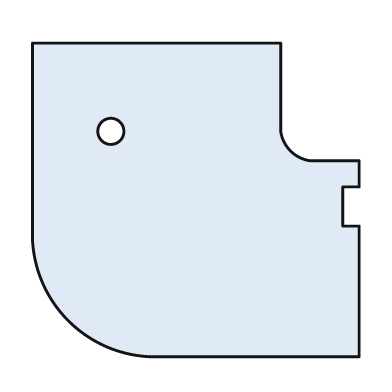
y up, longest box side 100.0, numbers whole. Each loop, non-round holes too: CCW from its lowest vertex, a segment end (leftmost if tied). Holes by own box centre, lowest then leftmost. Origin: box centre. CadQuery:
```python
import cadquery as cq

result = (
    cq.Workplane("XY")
    .moveTo(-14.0, -48.0)
    .lineTo(50.0, -48.0)
    .lineTo(50.0, -8.0)
    .lineTo(45.0, -8.0)
    .lineTo(45.0, 4.0)
    .lineTo(50.0, 4.0)
    .lineTo(50.0, 12.0)
    .lineTo(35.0, 12.0)
    .threePointArc((29.0, 15.0), (26.0, 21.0))
    .lineTo(26.0, 48.0)
    .lineTo(-50.0, 48.0)
    .lineTo(-50.0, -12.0)
    .threePointArc((-39.0, -37.0), (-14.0, -48.0))
    .close()
    .moveTo(-26.0, 21.0)
    .circle(4.0)
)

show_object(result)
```